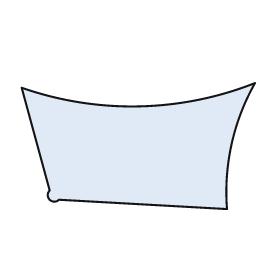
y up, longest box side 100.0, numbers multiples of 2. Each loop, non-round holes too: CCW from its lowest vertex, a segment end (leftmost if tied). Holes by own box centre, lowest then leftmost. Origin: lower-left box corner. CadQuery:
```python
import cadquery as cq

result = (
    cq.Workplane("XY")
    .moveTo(88.0, 0.0)
    .threePointArc((90.0, 28.0), (100.0, 54.0))
    .threePointArc((50.0, 44.0), (0.0, 52.0))
    .lineTo(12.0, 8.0)
    .threePointArc((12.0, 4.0), (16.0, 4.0))
    .close()
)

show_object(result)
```